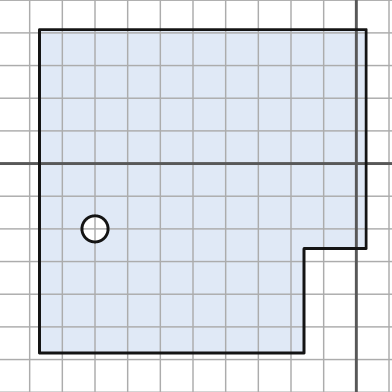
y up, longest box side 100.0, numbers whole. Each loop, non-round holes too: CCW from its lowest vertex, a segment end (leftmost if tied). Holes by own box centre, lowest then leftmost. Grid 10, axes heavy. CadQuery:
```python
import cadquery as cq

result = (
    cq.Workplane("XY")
    .moveTo(-97.0, -58.0)
    .lineTo(-16.0, -58.0)
    .lineTo(-16.0, -26.0)
    .lineTo(3.0, -26.0)
    .lineTo(3.0, 41.0)
    .lineTo(-97.0, 41.0)
    .close()
    .moveTo(-80.0, -20.0)
    .circle(4.0)
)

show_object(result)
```